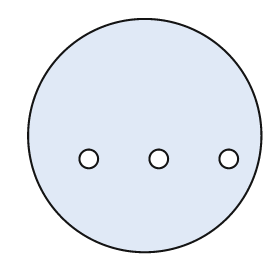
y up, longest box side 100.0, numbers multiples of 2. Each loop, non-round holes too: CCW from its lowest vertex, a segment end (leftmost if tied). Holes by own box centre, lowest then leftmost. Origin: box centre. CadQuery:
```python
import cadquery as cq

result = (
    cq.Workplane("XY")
    .moveTo(0.0, 0.0)
    .circle(50.0)
    .moveTo(-24.0, -10.0)
    .circle(4.0)
    .moveTo(6.0, -10.0)
    .circle(4.0)
    .moveTo(36.0, -10.0)
    .circle(4.0)
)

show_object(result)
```